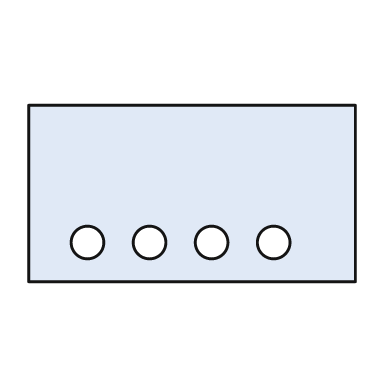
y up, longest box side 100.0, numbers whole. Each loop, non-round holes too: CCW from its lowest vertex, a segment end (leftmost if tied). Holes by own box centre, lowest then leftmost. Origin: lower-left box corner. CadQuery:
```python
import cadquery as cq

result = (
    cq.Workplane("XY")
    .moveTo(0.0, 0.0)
    .lineTo(100.0, 0.0)
    .lineTo(100.0, 54.0)
    .lineTo(0.0, 54.0)
    .close()
    .moveTo(18.0, 12.0)
    .circle(5.0)
    .moveTo(37.0, 12.0)
    .circle(5.0)
    .moveTo(56.0, 12.0)
    .circle(5.0)
    .moveTo(75.0, 12.0)
    .circle(5.0)
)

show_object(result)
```